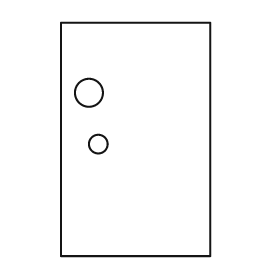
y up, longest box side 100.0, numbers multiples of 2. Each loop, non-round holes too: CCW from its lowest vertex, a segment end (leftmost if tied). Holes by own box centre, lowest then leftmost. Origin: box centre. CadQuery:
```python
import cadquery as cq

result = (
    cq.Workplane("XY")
    .moveTo(-32.0, -50.0)
    .lineTo(32.0, -50.0)
    .lineTo(32.0, 50.0)
    .lineTo(-32.0, 50.0)
    .close()
    .moveTo(-16.0, -2.0)
    .circle(4.0)
    .moveTo(-20.0, 20.0)
    .circle(6.0)
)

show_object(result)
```